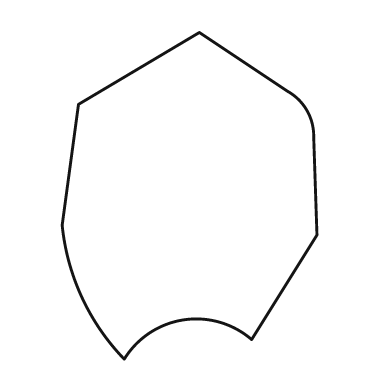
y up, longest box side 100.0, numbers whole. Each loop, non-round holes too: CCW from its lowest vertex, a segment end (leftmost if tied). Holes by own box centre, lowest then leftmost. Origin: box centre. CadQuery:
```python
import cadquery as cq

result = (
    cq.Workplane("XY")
    .moveTo(-20.0, -50.0)
    .threePointArc((-2.0, -38.0), (19.0, -44.0))
    .lineTo(39.0, -12.0)
    .lineTo(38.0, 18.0)
    .threePointArc((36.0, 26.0), (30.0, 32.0))
    .lineTo(3.0, 50.0)
    .lineTo(-34.0, 28.0)
    .lineTo(-39.0, -9.0)
    .threePointArc((-33.0, -31.0), (-20.0, -50.0))
    .close()
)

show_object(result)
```